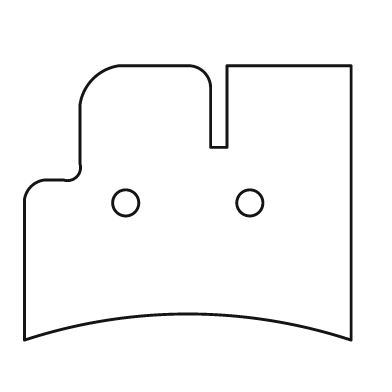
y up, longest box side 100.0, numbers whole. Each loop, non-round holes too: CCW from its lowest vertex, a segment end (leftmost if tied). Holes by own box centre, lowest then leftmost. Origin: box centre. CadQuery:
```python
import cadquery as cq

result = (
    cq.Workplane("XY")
    .moveTo(-50.0, -42.0)
    .threePointArc((0.0, -34.0), (50.0, -42.0))
    .lineTo(50.0, 42.0)
    .lineTo(12.0, 42.0)
    .lineTo(12.0, 17.0)
    .lineTo(7.0, 17.0)
    .lineTo(7.0, 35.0)
    .threePointArc((5.0, 40.0), (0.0, 42.0))
    .lineTo(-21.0, 42.0)
    .threePointArc((-29.0, 38.0), (-33.0, 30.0))
    .lineTo(-33.0, 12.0)
    .threePointArc((-34.0, 8.0), (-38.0, 7.0))
    .lineTo(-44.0, 7.0)
    .threePointArc((-48.0, 5.0), (-50.0, 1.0))
    .close()
    .moveTo(-19.0, 0.0)
    .circle(4.0)
    .moveTo(19.0, 0.0)
    .circle(4.0)
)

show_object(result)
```